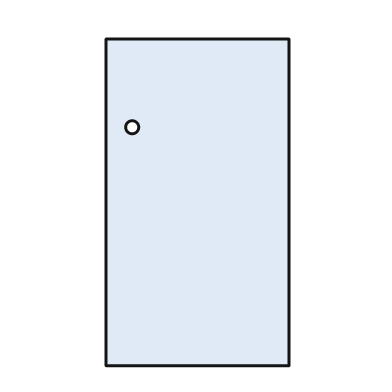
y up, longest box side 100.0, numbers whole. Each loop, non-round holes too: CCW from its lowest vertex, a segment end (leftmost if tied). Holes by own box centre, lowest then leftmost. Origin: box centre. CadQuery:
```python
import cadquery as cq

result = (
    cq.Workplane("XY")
    .moveTo(-28.0, -50.0)
    .lineTo(28.0, -50.0)
    .lineTo(28.0, 50.0)
    .lineTo(-28.0, 50.0)
    .close()
    .moveTo(-20.0, 23.0)
    .circle(2.0)
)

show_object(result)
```